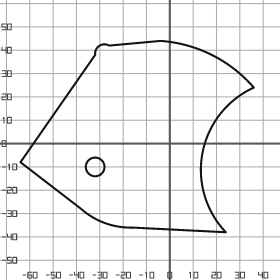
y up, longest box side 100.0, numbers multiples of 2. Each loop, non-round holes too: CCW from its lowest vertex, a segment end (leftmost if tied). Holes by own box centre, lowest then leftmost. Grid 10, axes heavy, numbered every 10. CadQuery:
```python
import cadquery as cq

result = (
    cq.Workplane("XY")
    .moveTo(24.0, -38.0)
    .threePointArc((14.0, -4.0), (36.0, 24.0))
    .threePointArc((18.0, 38.0), (-4.0, 44.0))
    .lineTo(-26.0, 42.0)
    .threePointArc((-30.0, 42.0), (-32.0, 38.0))
    .lineTo(-64.0, -8.0)
    .lineTo(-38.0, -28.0)
    .threePointArc((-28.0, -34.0), (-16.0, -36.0))
    .close()
    .moveTo(-32.0, -10.0)
    .circle(4.0)
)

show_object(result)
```